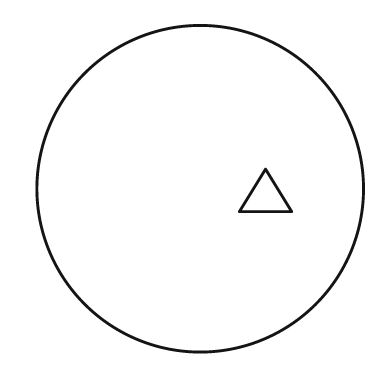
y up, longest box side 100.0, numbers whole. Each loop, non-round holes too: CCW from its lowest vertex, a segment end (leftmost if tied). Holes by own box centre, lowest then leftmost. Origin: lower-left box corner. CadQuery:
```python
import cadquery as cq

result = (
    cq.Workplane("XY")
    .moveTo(50.0, 50.0)
    .circle(50.0)
    .moveTo(62.0, 43.0)
    .lineTo(78.0, 43.0)
    .lineTo(70.0, 56.0)
    .close()
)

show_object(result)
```